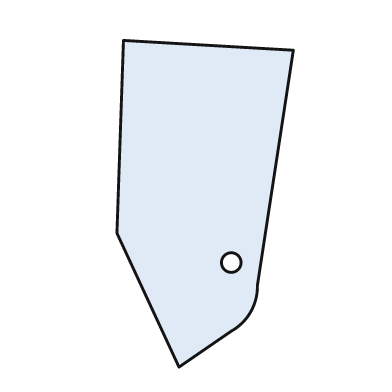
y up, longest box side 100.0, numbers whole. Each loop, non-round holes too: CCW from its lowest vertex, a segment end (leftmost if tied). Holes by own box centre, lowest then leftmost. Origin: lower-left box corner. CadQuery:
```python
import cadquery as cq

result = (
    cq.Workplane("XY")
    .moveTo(19.0, 0.0)
    .lineTo(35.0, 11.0)
    .threePointArc((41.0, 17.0), (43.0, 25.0))
    .lineTo(54.0, 97.0)
    .lineTo(2.0, 100.0)
    .lineTo(0.0, 41.0)
    .close()
    .moveTo(35.0, 32.0)
    .circle(3.0)
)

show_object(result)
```